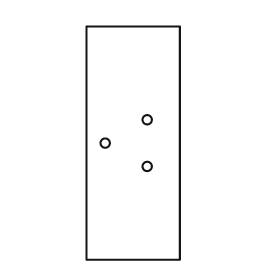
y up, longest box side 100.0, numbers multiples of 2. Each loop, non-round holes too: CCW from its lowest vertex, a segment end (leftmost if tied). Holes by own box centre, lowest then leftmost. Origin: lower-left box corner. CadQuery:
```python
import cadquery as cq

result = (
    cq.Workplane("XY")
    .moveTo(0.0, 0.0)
    .lineTo(40.0, 0.0)
    .lineTo(40.0, 100.0)
    .lineTo(0.0, 100.0)
    .close()
    .moveTo(26.0, 40.0)
    .circle(2.0)
    .moveTo(8.0, 50.0)
    .circle(2.0)
    .moveTo(26.0, 60.0)
    .circle(2.0)
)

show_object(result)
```